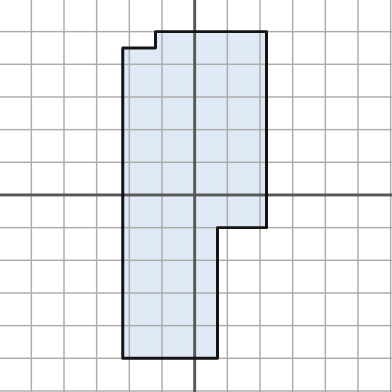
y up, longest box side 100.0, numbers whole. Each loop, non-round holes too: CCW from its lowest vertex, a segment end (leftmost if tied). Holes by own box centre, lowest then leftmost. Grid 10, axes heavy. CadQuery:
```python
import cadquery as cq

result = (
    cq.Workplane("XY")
    .moveTo(-22.0, -50.0)
    .lineTo(7.0, -50.0)
    .lineTo(7.0, -10.0)
    .lineTo(22.0, -10.0)
    .lineTo(22.0, 50.0)
    .lineTo(-12.0, 50.0)
    .lineTo(-12.0, 45.0)
    .lineTo(-22.0, 45.0)
    .close()
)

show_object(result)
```